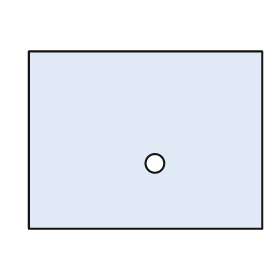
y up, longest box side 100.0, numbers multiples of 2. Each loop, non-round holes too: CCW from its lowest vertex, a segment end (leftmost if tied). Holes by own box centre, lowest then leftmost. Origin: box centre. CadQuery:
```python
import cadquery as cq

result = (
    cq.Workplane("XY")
    .moveTo(-50.0, -38.0)
    .lineTo(50.0, -38.0)
    .lineTo(50.0, 38.0)
    .lineTo(-50.0, 38.0)
    .close()
    .moveTo(4.0, -10.0)
    .circle(4.0)
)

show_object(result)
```